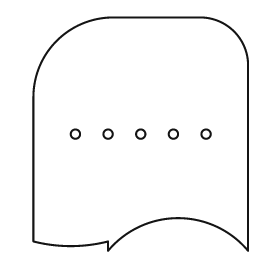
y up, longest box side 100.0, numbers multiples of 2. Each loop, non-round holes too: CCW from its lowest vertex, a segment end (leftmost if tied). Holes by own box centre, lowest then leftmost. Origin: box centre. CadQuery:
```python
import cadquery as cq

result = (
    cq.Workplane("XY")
    .moveTo(-14.0, -50.0)
    .threePointArc((16.0, -36.0), (46.0, -50.0))
    .lineTo(46.0, 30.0)
    .threePointArc((40.0, 44.0), (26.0, 50.0))
    .lineTo(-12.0, 50.0)
    .threePointArc((-36.0, 40.0), (-46.0, 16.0))
    .lineTo(-46.0, -46.0)
    .threePointArc((-30.0, -48.0), (-14.0, -46.0))
    .close()
    .moveTo(-28.0, 0.0)
    .circle(2.0)
    .moveTo(-14.0, 0.0)
    .circle(2.0)
    .moveTo(0.0, 0.0)
    .circle(2.0)
    .moveTo(14.0, 0.0)
    .circle(2.0)
    .moveTo(28.0, 0.0)
    .circle(2.0)
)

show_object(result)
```